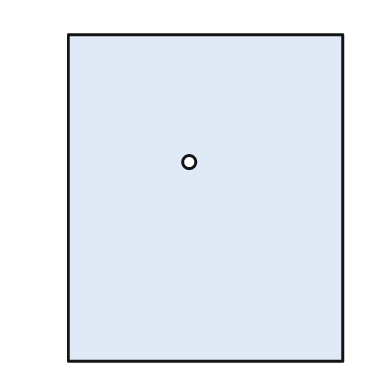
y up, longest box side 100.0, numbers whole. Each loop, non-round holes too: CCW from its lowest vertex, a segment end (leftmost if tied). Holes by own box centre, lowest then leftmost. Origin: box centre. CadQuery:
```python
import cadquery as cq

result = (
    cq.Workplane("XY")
    .moveTo(-42.0, -50.0)
    .lineTo(42.0, -50.0)
    .lineTo(42.0, 50.0)
    .lineTo(-42.0, 50.0)
    .close()
    .moveTo(-5.0, 11.0)
    .circle(2.0)
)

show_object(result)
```